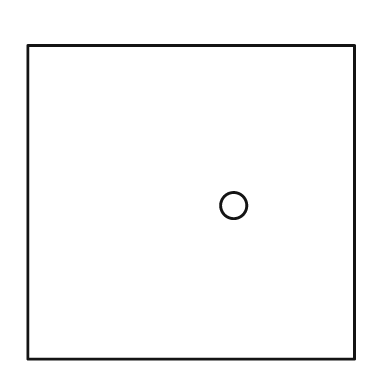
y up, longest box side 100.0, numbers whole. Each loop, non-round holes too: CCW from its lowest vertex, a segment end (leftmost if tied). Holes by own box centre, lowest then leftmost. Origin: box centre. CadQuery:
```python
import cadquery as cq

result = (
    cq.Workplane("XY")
    .moveTo(-50.0, -48.0)
    .lineTo(50.0, -48.0)
    .lineTo(50.0, 48.0)
    .lineTo(-50.0, 48.0)
    .close()
    .moveTo(13.0, -1.0)
    .circle(4.0)
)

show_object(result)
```